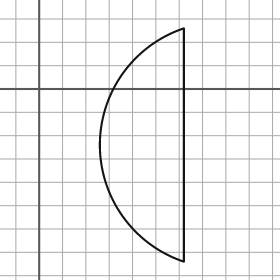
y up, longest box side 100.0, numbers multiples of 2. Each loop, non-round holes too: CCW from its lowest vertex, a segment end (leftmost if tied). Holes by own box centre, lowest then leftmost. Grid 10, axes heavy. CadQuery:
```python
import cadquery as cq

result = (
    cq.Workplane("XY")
    .moveTo(62.0, -74.0)
    .lineTo(62.0, 26.0)
    .threePointArc((26.0, -24.0), (62.0, -74.0))
    .close()
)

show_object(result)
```